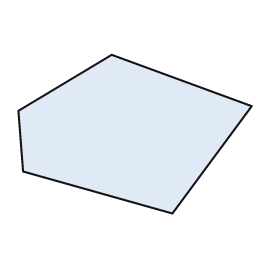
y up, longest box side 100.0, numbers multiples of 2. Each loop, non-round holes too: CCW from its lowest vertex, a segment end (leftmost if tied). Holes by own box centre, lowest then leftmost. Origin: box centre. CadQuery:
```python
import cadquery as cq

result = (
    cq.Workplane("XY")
    .moveTo(16.0, -34.0)
    .lineTo(50.0, 12.0)
    .lineTo(-10.0, 34.0)
    .lineTo(-50.0, 10.0)
    .lineTo(-48.0, -16.0)
    .close()
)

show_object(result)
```